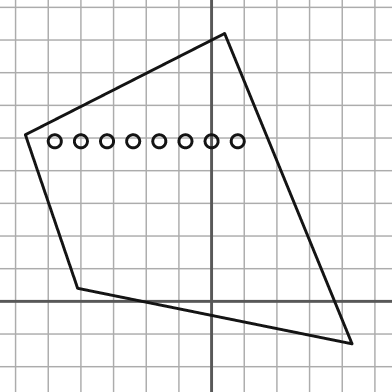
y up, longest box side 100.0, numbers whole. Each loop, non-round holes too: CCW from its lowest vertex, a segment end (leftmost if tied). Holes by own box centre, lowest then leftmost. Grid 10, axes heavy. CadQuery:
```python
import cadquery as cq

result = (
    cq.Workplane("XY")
    .moveTo(43.0, -13.0)
    .lineTo(4.0, 82.0)
    .lineTo(-57.0, 51.0)
    .lineTo(-41.0, 4.0)
    .close()
    .moveTo(-48.0, 49.0)
    .circle(2.0)
    .moveTo(-40.0, 49.0)
    .circle(2.0)
    .moveTo(-32.0, 49.0)
    .circle(2.0)
    .moveTo(-24.0, 49.0)
    .circle(2.0)
    .moveTo(-16.0, 49.0)
    .circle(2.0)
    .moveTo(-8.0, 49.0)
    .circle(2.0)
    .moveTo(0.0, 49.0)
    .circle(2.0)
    .moveTo(8.0, 49.0)
    .circle(2.0)
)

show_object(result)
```